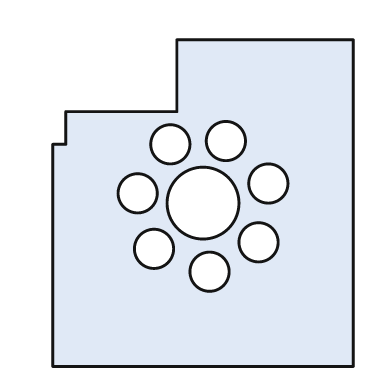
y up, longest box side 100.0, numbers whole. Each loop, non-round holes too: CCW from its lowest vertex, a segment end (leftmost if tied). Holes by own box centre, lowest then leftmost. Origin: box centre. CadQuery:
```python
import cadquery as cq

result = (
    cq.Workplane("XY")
    .moveTo(-46.0, -50.0)
    .lineTo(46.0, -50.0)
    .lineTo(46.0, 50.0)
    .lineTo(-8.0, 50.0)
    .lineTo(-8.0, 28.0)
    .lineTo(-42.0, 28.0)
    .lineTo(-42.0, 18.0)
    .lineTo(-46.0, 18.0)
    .close()
    .moveTo(2.0, -21.0)
    .circle(6.0)
    .moveTo(-15.0, -14.0)
    .circle(6.0)
    .moveTo(17.0, -12.0)
    .circle(6.0)
    .moveTo(0.0, 0.0)
    .circle(11.0)
    .moveTo(-20.0, 3.0)
    .circle(6.0)
    .moveTo(20.0, 6.0)
    .circle(6.0)
    .moveTo(-10.0, 18.0)
    .circle(6.0)
    .moveTo(7.0, 19.0)
    .circle(6.0)
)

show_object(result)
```